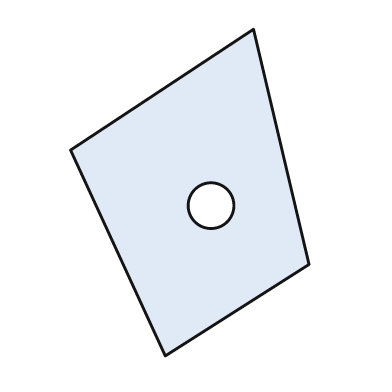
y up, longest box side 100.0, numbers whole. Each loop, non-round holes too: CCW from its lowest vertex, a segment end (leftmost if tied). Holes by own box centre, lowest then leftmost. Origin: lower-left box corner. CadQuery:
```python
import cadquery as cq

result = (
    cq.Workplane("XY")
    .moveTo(29.0, 0.0)
    .lineTo(73.0, 28.0)
    .lineTo(56.0, 100.0)
    .lineTo(0.0, 63.0)
    .close()
    .moveTo(43.0, 46.0)
    .circle(7.0)
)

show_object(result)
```